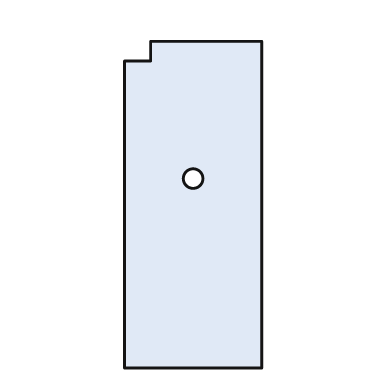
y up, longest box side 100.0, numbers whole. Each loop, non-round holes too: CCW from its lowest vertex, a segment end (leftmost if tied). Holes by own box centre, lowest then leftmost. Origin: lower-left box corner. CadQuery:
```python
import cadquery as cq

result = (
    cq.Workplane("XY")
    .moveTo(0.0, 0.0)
    .lineTo(42.0, 0.0)
    .lineTo(42.0, 100.0)
    .lineTo(8.0, 100.0)
    .lineTo(8.0, 94.0)
    .lineTo(0.0, 94.0)
    .close()
    .moveTo(21.0, 58.0)
    .circle(3.0)
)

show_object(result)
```